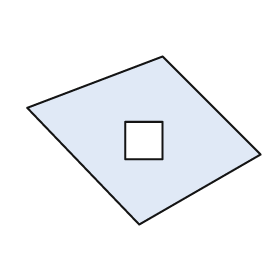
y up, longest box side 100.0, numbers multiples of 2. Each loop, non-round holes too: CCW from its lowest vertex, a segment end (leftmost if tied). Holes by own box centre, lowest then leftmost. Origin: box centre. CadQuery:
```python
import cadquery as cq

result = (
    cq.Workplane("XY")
    .moveTo(-2.0, -36.0)
    .lineTo(50.0, -6.0)
    .lineTo(8.0, 36.0)
    .lineTo(-50.0, 14.0)
    .close()
    .moveTo(-8.0, -8.0)
    .lineTo(8.0, -8.0)
    .lineTo(8.0, 8.0)
    .lineTo(-8.0, 8.0)
    .close()
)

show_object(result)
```